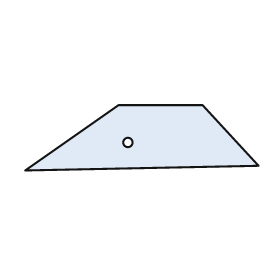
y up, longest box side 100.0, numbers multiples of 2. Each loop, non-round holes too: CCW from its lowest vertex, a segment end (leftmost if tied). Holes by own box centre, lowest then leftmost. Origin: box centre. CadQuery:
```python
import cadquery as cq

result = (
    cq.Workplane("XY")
    .moveTo(-50.0, -14.0)
    .lineTo(50.0, -12.0)
    .lineTo(26.0, 14.0)
    .lineTo(-10.0, 14.0)
    .close()
    .moveTo(-6.0, -2.0)
    .circle(2.0)
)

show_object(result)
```